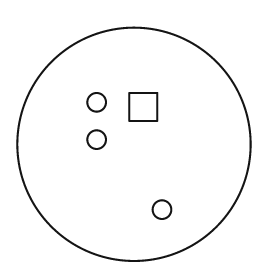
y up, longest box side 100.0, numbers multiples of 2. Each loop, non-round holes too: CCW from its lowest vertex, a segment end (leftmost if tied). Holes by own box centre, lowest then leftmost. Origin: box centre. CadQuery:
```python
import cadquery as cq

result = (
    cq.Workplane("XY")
    .moveTo(0.0, 0.0)
    .circle(50.0)
    .moveTo(12.0, -28.0)
    .circle(4.0)
    .moveTo(-16.0, 2.0)
    .circle(4.0)
    .moveTo(-2.0, 10.0)
    .lineTo(10.0, 10.0)
    .lineTo(10.0, 22.0)
    .lineTo(-2.0, 22.0)
    .close()
    .moveTo(-16.0, 18.0)
    .circle(4.0)
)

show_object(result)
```